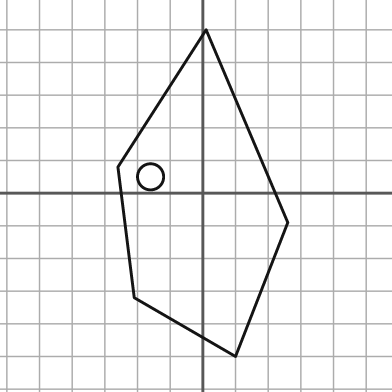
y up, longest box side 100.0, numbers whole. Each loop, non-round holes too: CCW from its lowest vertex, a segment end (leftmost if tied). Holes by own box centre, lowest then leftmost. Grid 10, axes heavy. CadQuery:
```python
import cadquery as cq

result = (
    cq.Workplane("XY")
    .moveTo(10.0, -50.0)
    .lineTo(26.0, -9.0)
    .lineTo(1.0, 50.0)
    .lineTo(-26.0, 8.0)
    .lineTo(-21.0, -32.0)
    .close()
    .moveTo(-16.0, 5.0)
    .circle(4.0)
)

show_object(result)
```